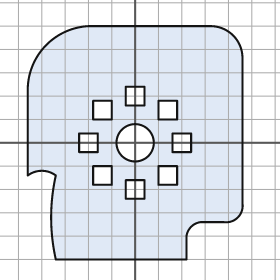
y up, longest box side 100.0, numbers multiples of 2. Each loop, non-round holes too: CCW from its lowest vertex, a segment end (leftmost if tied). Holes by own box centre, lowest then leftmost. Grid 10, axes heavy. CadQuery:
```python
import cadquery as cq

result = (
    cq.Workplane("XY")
    .moveTo(-34.0, -50.0)
    .lineTo(22.0, -50.0)
    .lineTo(22.0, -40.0)
    .threePointArc((24.0, -36.0), (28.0, -34.0))
    .lineTo(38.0, -34.0)
    .threePointArc((44.0, -32.0), (46.0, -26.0))
    .lineTo(46.0, 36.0)
    .threePointArc((42.0, 46.0), (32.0, 50.0))
    .lineTo(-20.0, 50.0)
    .threePointArc((-38.0, 42.0), (-46.0, 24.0))
    .lineTo(-46.0, -14.0)
    .threePointArc((-40.0, -12.0), (-34.0, -14.0))
    .threePointArc((-36.0, -32.0), (-34.0, -50.0))
    .close()
    .moveTo(-4.0, -24.0)
    .lineTo(4.0, -24.0)
    .lineTo(4.0, -16.0)
    .lineTo(-4.0, -16.0)
    .close()
    .moveTo(-18.0, -18.0)
    .lineTo(-10.0, -18.0)
    .lineTo(-10.0, -10.0)
    .lineTo(-18.0, -10.0)
    .close()
    .moveTo(10.0, -18.0)
    .lineTo(18.0, -18.0)
    .lineTo(18.0, -10.0)
    .lineTo(10.0, -10.0)
    .close()
    .moveTo(-24.0, -4.0)
    .lineTo(-16.0, -4.0)
    .lineTo(-16.0, 4.0)
    .lineTo(-24.0, 4.0)
    .close()
    .moveTo(0.0, 0.0)
    .circle(8.0)
    .moveTo(16.0, -4.0)
    .lineTo(24.0, -4.0)
    .lineTo(24.0, 4.0)
    .lineTo(16.0, 4.0)
    .close()
    .moveTo(-18.0, 10.0)
    .lineTo(-10.0, 10.0)
    .lineTo(-10.0, 18.0)
    .lineTo(-18.0, 18.0)
    .close()
    .moveTo(10.0, 10.0)
    .lineTo(18.0, 10.0)
    .lineTo(18.0, 18.0)
    .lineTo(10.0, 18.0)
    .close()
    .moveTo(-4.0, 16.0)
    .lineTo(4.0, 16.0)
    .lineTo(4.0, 24.0)
    .lineTo(-4.0, 24.0)
    .close()
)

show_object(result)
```